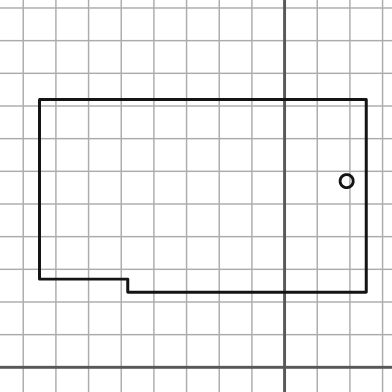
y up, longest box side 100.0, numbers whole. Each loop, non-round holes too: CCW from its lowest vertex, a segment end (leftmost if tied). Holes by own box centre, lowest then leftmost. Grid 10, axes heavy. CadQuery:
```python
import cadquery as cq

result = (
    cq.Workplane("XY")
    .moveTo(-48.0, 23.0)
    .lineTo(25.0, 23.0)
    .lineTo(25.0, 82.0)
    .lineTo(-75.0, 82.0)
    .lineTo(-75.0, 27.0)
    .lineTo(-48.0, 27.0)
    .close()
    .moveTo(19.0, 57.0)
    .circle(2.0)
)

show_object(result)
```